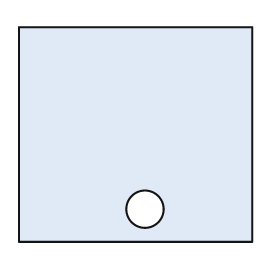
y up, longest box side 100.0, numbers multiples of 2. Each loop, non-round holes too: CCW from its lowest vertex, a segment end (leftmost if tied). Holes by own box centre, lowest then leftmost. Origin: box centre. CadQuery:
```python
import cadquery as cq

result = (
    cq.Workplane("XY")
    .moveTo(-50.0, -46.0)
    .lineTo(50.0, -46.0)
    .lineTo(50.0, 46.0)
    .lineTo(-50.0, 46.0)
    .close()
    .moveTo(4.0, -32.0)
    .circle(8.0)
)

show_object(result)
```